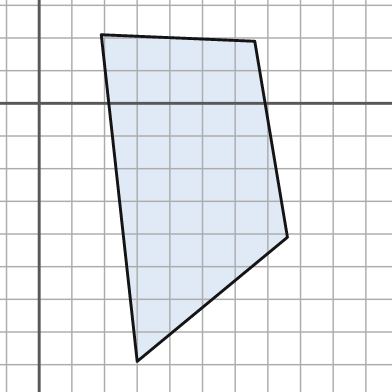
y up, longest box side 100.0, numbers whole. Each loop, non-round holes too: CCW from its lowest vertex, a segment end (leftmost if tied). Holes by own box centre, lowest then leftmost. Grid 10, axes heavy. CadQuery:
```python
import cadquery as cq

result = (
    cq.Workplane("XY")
    .moveTo(30.0, -79.0)
    .lineTo(76.0, -41.0)
    .lineTo(66.0, 19.0)
    .lineTo(19.0, 21.0)
    .close()
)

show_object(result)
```